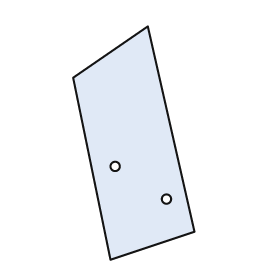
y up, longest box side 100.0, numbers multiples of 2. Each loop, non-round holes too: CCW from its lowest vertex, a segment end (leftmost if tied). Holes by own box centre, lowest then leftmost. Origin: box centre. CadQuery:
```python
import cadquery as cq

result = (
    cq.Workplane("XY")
    .moveTo(-10.0, -50.0)
    .lineTo(26.0, -38.0)
    .lineTo(6.0, 50.0)
    .lineTo(-26.0, 28.0)
    .close()
    .moveTo(14.0, -24.0)
    .circle(2.0)
    .moveTo(-8.0, -10.0)
    .circle(2.0)
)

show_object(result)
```